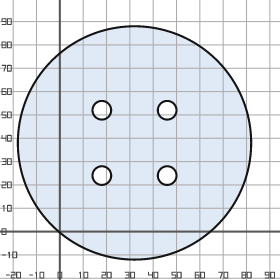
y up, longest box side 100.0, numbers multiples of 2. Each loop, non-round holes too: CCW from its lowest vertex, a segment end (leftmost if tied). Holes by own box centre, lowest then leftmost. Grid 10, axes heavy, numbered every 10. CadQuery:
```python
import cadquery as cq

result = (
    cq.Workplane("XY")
    .moveTo(32.0, 38.0)
    .circle(50.0)
    .moveTo(18.0, 24.0)
    .circle(4.0)
    .moveTo(46.0, 24.0)
    .circle(4.0)
    .moveTo(18.0, 52.0)
    .circle(4.0)
    .moveTo(46.0, 52.0)
    .circle(4.0)
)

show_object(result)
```